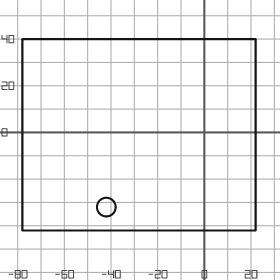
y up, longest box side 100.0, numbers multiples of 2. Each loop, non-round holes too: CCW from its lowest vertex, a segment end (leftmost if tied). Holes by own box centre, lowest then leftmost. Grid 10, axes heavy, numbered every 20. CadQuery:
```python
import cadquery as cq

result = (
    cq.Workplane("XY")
    .moveTo(-78.0, -42.0)
    .lineTo(22.0, -42.0)
    .lineTo(22.0, 40.0)
    .lineTo(-78.0, 40.0)
    .close()
    .moveTo(-42.0, -32.0)
    .circle(4.0)
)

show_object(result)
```